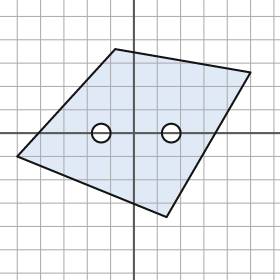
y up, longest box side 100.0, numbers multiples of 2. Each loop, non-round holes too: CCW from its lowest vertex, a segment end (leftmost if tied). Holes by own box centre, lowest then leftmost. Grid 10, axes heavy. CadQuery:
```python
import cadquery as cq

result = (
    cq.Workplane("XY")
    .moveTo(14.0, -36.0)
    .lineTo(50.0, 26.0)
    .lineTo(-8.0, 36.0)
    .lineTo(-50.0, -10.0)
    .close()
    .moveTo(-14.0, 0.0)
    .circle(4.0)
    .moveTo(16.0, 0.0)
    .circle(4.0)
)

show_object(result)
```